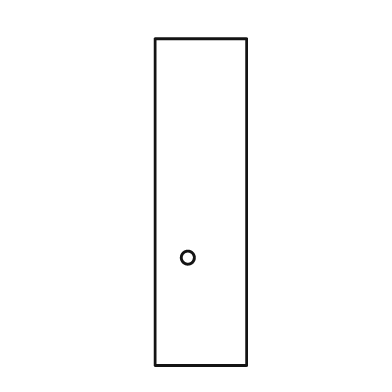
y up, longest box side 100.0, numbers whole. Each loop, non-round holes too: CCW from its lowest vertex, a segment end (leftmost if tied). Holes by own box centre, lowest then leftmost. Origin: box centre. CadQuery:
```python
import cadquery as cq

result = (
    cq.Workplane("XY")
    .moveTo(-14.0, -50.0)
    .lineTo(14.0, -50.0)
    .lineTo(14.0, 50.0)
    .lineTo(-14.0, 50.0)
    .close()
    .moveTo(-4.0, -17.0)
    .circle(2.0)
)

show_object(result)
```